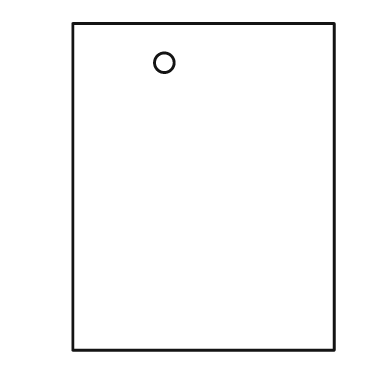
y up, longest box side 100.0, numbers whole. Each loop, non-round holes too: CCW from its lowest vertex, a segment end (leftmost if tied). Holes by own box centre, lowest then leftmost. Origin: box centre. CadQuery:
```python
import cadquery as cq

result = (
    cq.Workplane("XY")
    .moveTo(-40.0, -50.0)
    .lineTo(40.0, -50.0)
    .lineTo(40.0, 50.0)
    .lineTo(-40.0, 50.0)
    .close()
    .moveTo(-12.0, 38.0)
    .circle(3.0)
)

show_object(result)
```